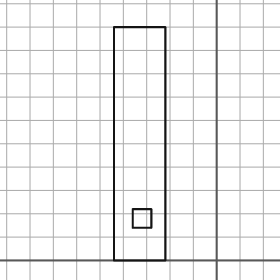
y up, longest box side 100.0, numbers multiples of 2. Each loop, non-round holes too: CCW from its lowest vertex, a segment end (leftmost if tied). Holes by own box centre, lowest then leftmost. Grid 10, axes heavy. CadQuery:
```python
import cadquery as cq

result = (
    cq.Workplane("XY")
    .moveTo(-44.0, 0.0)
    .lineTo(-22.0, 0.0)
    .lineTo(-22.0, 100.0)
    .lineTo(-44.0, 100.0)
    .close()
    .moveTo(-36.0, 14.0)
    .lineTo(-28.0, 14.0)
    .lineTo(-28.0, 22.0)
    .lineTo(-36.0, 22.0)
    .close()
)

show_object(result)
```